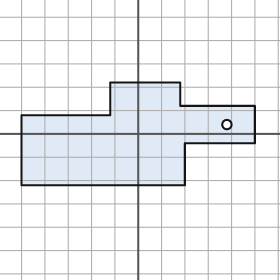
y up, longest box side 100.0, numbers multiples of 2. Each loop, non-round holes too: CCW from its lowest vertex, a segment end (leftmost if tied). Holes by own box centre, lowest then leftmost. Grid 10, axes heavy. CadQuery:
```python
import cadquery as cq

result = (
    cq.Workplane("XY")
    .moveTo(-50.0, -22.0)
    .lineTo(20.0, -22.0)
    .lineTo(20.0, -4.0)
    .lineTo(50.0, -4.0)
    .lineTo(50.0, 12.0)
    .lineTo(18.0, 12.0)
    .lineTo(18.0, 22.0)
    .lineTo(-12.0, 22.0)
    .lineTo(-12.0, 8.0)
    .lineTo(-50.0, 8.0)
    .close()
    .moveTo(38.0, 4.0)
    .circle(2.0)
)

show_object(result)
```